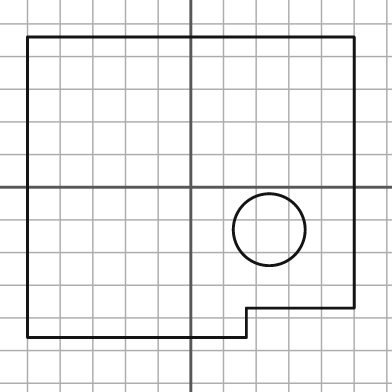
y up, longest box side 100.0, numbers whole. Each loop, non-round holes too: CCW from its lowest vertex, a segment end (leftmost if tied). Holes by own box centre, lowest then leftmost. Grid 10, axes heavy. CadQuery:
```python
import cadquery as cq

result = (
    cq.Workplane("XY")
    .moveTo(-50.0, -46.0)
    .lineTo(17.0, -46.0)
    .lineTo(17.0, -37.0)
    .lineTo(50.0, -37.0)
    .lineTo(50.0, 46.0)
    .lineTo(-50.0, 46.0)
    .close()
    .moveTo(24.0, -13.0)
    .circle(11.0)
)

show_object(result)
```